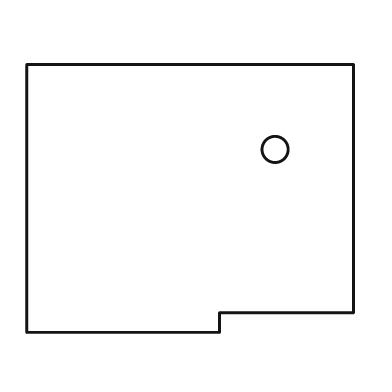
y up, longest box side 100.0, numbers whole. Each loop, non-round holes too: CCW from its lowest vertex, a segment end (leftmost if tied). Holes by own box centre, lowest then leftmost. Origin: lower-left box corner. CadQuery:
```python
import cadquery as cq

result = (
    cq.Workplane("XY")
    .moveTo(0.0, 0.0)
    .lineTo(59.0, 0.0)
    .lineTo(59.0, 6.0)
    .lineTo(100.0, 6.0)
    .lineTo(100.0, 82.0)
    .lineTo(0.0, 82.0)
    .close()
    .moveTo(76.0, 56.0)
    .circle(4.0)
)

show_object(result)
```